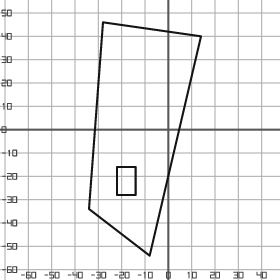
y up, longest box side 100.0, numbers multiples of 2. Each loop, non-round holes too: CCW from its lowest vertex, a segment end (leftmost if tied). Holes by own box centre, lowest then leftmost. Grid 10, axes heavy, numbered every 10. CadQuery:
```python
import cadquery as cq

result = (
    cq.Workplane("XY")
    .moveTo(-8.0, -54.0)
    .lineTo(14.0, 40.0)
    .lineTo(-28.0, 46.0)
    .lineTo(-34.0, -34.0)
    .close()
    .moveTo(-22.0, -28.0)
    .lineTo(-14.0, -28.0)
    .lineTo(-14.0, -16.0)
    .lineTo(-22.0, -16.0)
    .close()
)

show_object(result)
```